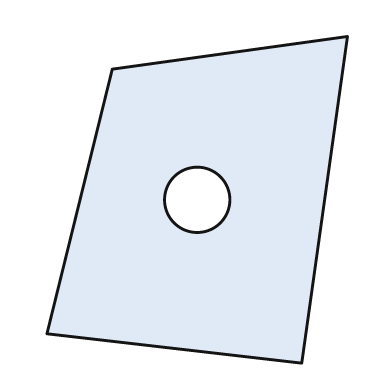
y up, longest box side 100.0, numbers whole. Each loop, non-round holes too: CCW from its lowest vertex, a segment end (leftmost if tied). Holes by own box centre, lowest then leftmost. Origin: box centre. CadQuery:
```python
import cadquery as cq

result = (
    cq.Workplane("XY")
    .moveTo(32.0, -50.0)
    .lineTo(46.0, 50.0)
    .lineTo(-26.0, 40.0)
    .lineTo(-46.0, -41.0)
    .close()
    .moveTo(0.0, 0.0)
    .circle(10.0)
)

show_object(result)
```